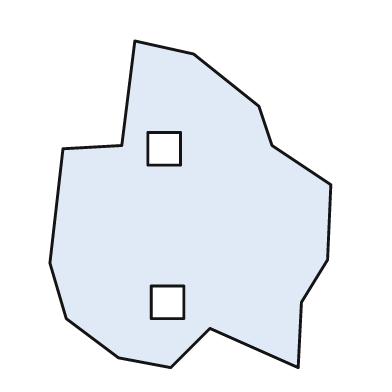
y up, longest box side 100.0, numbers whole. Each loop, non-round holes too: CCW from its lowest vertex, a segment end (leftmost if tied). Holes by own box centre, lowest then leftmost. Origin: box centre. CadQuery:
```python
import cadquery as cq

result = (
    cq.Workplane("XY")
    .moveTo(-6.0, -50.0)
    .lineTo(6.0, -38.0)
    .lineTo(33.0, -50.0)
    .lineTo(34.0, -30.0)
    .lineTo(42.0, -17.0)
    .lineTo(43.0, 6.0)
    .lineTo(25.0, 18.0)
    .lineTo(21.0, 30.0)
    .lineTo(1.0, 46.0)
    .lineTo(-17.0, 50.0)
    .lineTo(-21.0, 18.0)
    .lineTo(-39.0, 17.0)
    .lineTo(-43.0, -18.0)
    .lineTo(-38.0, -35.0)
    .lineTo(-22.0, -47.0)
    .close()
    .moveTo(-12.0, -35.0)
    .lineTo(-2.0, -35.0)
    .lineTo(-2.0, -25.0)
    .lineTo(-12.0, -25.0)
    .close()
    .moveTo(-13.0, 12.0)
    .lineTo(-3.0, 12.0)
    .lineTo(-3.0, 22.0)
    .lineTo(-13.0, 22.0)
    .close()
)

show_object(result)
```